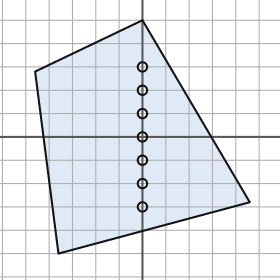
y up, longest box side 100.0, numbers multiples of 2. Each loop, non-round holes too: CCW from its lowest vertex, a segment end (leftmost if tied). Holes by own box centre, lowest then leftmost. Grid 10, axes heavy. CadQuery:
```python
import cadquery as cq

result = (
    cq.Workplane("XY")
    .moveTo(-36.0, -50.0)
    .lineTo(46.0, -28.0)
    .lineTo(0.0, 50.0)
    .lineTo(-46.0, 28.0)
    .close()
    .moveTo(0.0, -30.0)
    .circle(2.0)
    .moveTo(0.0, -20.0)
    .circle(2.0)
    .moveTo(0.0, -10.0)
    .circle(2.0)
    .moveTo(0.0, 0.0)
    .circle(2.0)
    .moveTo(0.0, 10.0)
    .circle(2.0)
    .moveTo(0.0, 20.0)
    .circle(2.0)
    .moveTo(0.0, 30.0)
    .circle(2.0)
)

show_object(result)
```